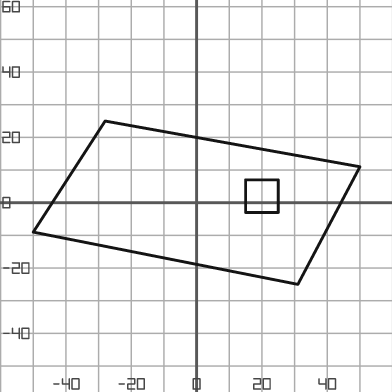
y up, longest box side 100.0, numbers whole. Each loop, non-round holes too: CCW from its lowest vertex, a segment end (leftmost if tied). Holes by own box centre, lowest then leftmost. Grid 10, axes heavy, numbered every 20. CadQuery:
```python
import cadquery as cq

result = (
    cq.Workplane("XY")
    .moveTo(31.0, -25.0)
    .lineTo(50.0, 11.0)
    .lineTo(-28.0, 25.0)
    .lineTo(-50.0, -9.0)
    .close()
    .moveTo(15.0, -3.0)
    .lineTo(25.0, -3.0)
    .lineTo(25.0, 7.0)
    .lineTo(15.0, 7.0)
    .close()
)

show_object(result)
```